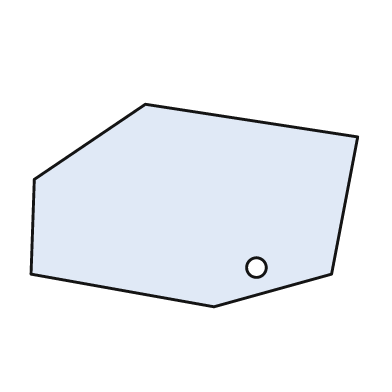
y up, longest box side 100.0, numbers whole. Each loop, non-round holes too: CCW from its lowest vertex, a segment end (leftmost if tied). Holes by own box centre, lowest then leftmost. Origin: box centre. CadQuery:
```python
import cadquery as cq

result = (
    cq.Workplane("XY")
    .moveTo(6.0, -31.0)
    .lineTo(42.0, -21.0)
    .lineTo(50.0, 21.0)
    .lineTo(-15.0, 31.0)
    .lineTo(-49.0, 8.0)
    .lineTo(-50.0, -21.0)
    .close()
    .moveTo(19.0, -19.0)
    .circle(3.0)
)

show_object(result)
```